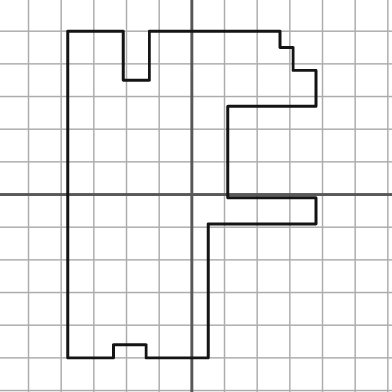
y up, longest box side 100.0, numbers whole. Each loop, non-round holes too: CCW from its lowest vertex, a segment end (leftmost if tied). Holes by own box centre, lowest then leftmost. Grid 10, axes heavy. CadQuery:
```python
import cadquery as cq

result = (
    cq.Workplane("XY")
    .moveTo(-38.0, -50.0)
    .lineTo(-24.0, -50.0)
    .lineTo(-24.0, -46.0)
    .lineTo(-14.0, -46.0)
    .lineTo(-14.0, -50.0)
    .lineTo(5.0, -50.0)
    .lineTo(5.0, -9.0)
    .lineTo(38.0, -9.0)
    .lineTo(38.0, -1.0)
    .lineTo(11.0, -1.0)
    .lineTo(11.0, 27.0)
    .lineTo(38.0, 27.0)
    .lineTo(38.0, 38.0)
    .lineTo(31.0, 38.0)
    .lineTo(31.0, 45.0)
    .lineTo(27.0, 45.0)
    .lineTo(27.0, 50.0)
    .lineTo(-13.0, 50.0)
    .lineTo(-13.0, 35.0)
    .lineTo(-21.0, 35.0)
    .lineTo(-21.0, 50.0)
    .lineTo(-38.0, 50.0)
    .close()
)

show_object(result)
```